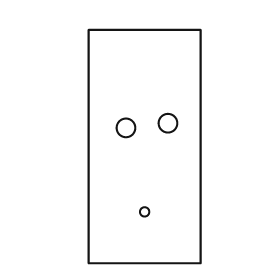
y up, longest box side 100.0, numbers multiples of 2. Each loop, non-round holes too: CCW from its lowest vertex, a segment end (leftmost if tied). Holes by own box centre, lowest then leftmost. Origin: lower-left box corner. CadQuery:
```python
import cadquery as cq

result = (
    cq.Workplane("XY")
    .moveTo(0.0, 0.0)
    .lineTo(48.0, 0.0)
    .lineTo(48.0, 100.0)
    .lineTo(0.0, 100.0)
    .close()
    .moveTo(24.0, 22.0)
    .circle(2.0)
    .moveTo(16.0, 58.0)
    .circle(4.0)
    .moveTo(34.0, 60.0)
    .circle(4.0)
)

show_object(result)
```